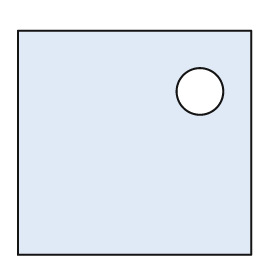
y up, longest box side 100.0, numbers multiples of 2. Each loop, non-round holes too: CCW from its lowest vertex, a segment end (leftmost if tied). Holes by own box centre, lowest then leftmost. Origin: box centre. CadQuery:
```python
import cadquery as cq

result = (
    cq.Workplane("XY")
    .moveTo(-50.0, -48.0)
    .lineTo(50.0, -48.0)
    .lineTo(50.0, 48.0)
    .lineTo(-50.0, 48.0)
    .close()
    .moveTo(28.0, 22.0)
    .circle(10.0)
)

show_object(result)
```